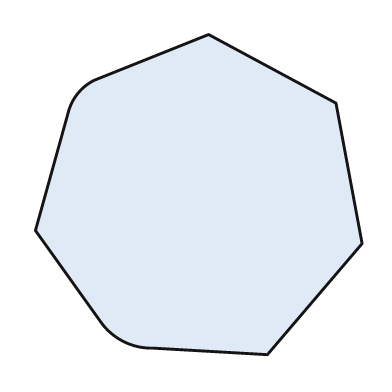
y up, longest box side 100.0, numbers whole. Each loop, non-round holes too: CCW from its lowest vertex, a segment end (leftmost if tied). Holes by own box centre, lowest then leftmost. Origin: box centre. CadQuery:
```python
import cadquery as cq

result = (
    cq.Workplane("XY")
    .moveTo(21.0, -49.0)
    .lineTo(50.0, -15.0)
    .lineTo(42.0, 28.0)
    .lineTo(3.0, 49.0)
    .lineTo(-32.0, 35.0)
    .threePointArc((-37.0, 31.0), (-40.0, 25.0))
    .lineTo(-50.0, -11.0)
    .lineTo(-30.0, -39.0)
    .threePointArc((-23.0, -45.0), (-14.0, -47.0))
    .close()
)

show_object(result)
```